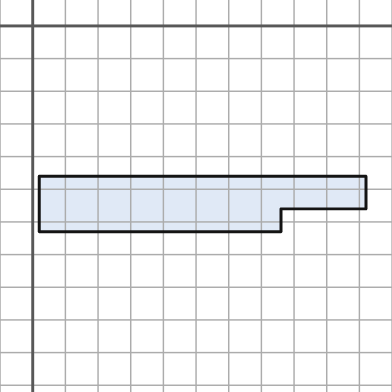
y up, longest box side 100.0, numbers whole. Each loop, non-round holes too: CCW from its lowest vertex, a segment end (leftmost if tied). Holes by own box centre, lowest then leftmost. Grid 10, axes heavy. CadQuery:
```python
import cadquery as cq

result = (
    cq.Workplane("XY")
    .moveTo(2.0, -63.0)
    .lineTo(76.0, -63.0)
    .lineTo(76.0, -56.0)
    .lineTo(102.0, -56.0)
    .lineTo(102.0, -46.0)
    .lineTo(2.0, -46.0)
    .close()
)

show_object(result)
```